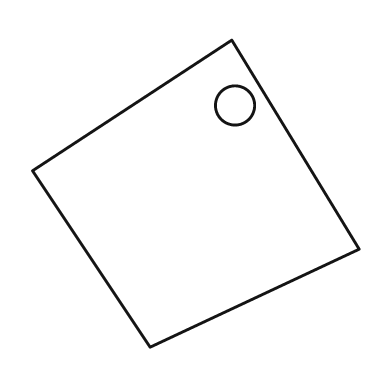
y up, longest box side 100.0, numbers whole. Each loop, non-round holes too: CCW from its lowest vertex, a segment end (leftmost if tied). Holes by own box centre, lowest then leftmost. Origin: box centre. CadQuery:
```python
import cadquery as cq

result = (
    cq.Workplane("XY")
    .moveTo(-14.0, -47.0)
    .lineTo(50.0, -17.0)
    .lineTo(11.0, 47.0)
    .lineTo(-50.0, 7.0)
    .close()
    .moveTo(12.0, 27.0)
    .circle(6.0)
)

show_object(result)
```